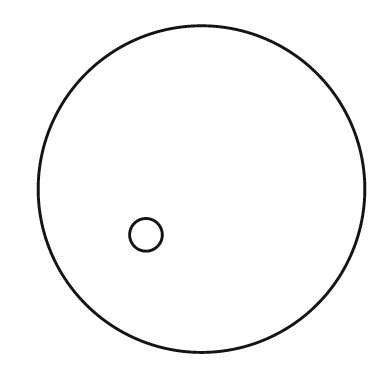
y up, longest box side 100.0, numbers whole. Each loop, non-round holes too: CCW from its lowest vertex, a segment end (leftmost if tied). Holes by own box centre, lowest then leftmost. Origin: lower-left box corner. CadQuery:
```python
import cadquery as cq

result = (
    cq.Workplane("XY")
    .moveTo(50.0, 50.0)
    .circle(50.0)
    .moveTo(33.0, 36.0)
    .circle(5.0)
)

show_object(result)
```